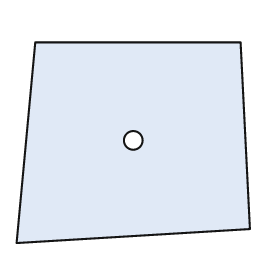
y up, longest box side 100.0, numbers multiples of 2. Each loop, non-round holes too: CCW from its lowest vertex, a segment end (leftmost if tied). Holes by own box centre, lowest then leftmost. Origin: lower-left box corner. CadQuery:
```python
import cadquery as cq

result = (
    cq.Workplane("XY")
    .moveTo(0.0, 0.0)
    .lineTo(100.0, 6.0)
    .lineTo(96.0, 86.0)
    .lineTo(8.0, 86.0)
    .close()
    .moveTo(50.0, 44.0)
    .circle(4.0)
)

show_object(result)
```